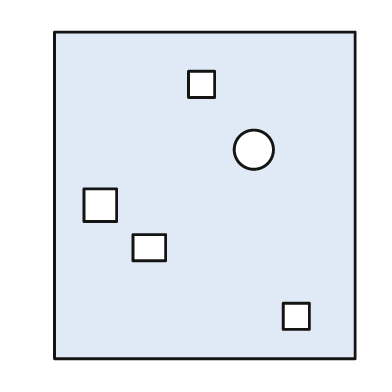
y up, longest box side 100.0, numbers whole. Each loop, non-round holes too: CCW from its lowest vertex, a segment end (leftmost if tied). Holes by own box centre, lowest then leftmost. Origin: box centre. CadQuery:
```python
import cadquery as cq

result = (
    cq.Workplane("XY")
    .moveTo(-46.0, -50.0)
    .lineTo(46.0, -50.0)
    .lineTo(46.0, 50.0)
    .lineTo(-46.0, 50.0)
    .close()
    .moveTo(24.0, -41.0)
    .lineTo(32.0, -41.0)
    .lineTo(32.0, -33.0)
    .lineTo(24.0, -33.0)
    .close()
    .moveTo(-22.0, -20.0)
    .lineTo(-12.0, -20.0)
    .lineTo(-12.0, -12.0)
    .lineTo(-22.0, -12.0)
    .close()
    .moveTo(-37.0, -8.0)
    .lineTo(-27.0, -8.0)
    .lineTo(-27.0, 2.0)
    .lineTo(-37.0, 2.0)
    .close()
    .moveTo(15.0, 14.0)
    .circle(6.0)
    .moveTo(-5.0, 30.0)
    .lineTo(3.0, 30.0)
    .lineTo(3.0, 38.0)
    .lineTo(-5.0, 38.0)
    .close()
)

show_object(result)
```